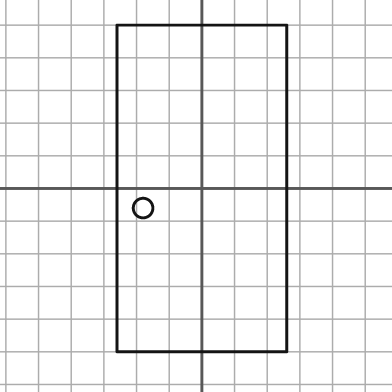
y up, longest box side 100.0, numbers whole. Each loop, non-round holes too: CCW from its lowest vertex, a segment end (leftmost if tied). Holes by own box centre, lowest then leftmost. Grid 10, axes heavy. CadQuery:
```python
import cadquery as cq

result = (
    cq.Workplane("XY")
    .moveTo(-26.0, -50.0)
    .lineTo(26.0, -50.0)
    .lineTo(26.0, 50.0)
    .lineTo(-26.0, 50.0)
    .close()
    .moveTo(-18.0, -6.0)
    .circle(3.0)
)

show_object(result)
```